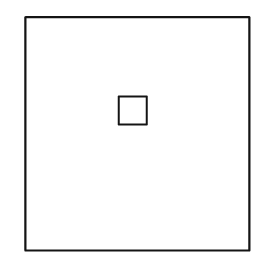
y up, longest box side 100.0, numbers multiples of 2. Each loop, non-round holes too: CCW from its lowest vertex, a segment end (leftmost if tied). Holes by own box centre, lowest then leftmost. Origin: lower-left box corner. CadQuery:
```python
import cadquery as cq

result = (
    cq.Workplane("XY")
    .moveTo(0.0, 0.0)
    .lineTo(96.0, 0.0)
    .lineTo(96.0, 100.0)
    .lineTo(0.0, 100.0)
    .close()
    .moveTo(40.0, 54.0)
    .lineTo(52.0, 54.0)
    .lineTo(52.0, 66.0)
    .lineTo(40.0, 66.0)
    .close()
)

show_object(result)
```